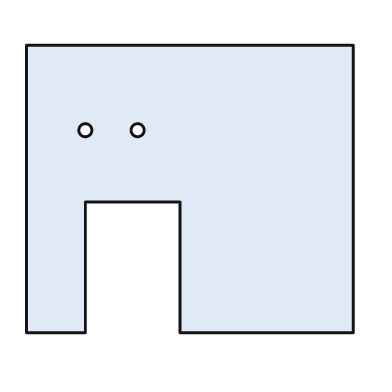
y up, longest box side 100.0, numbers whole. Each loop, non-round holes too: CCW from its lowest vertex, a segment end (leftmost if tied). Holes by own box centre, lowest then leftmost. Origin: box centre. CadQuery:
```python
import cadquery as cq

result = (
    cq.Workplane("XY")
    .moveTo(-50.0, -44.0)
    .lineTo(-32.0, -44.0)
    .lineTo(-32.0, -4.0)
    .lineTo(-3.0, -4.0)
    .lineTo(-3.0, -44.0)
    .lineTo(50.0, -44.0)
    .lineTo(50.0, 44.0)
    .lineTo(-50.0, 44.0)
    .close()
    .moveTo(-32.0, 18.0)
    .circle(2.0)
    .moveTo(-16.0, 18.0)
    .circle(2.0)
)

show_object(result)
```